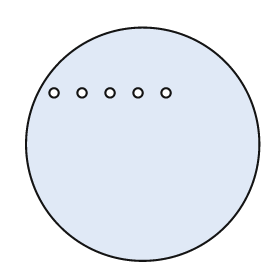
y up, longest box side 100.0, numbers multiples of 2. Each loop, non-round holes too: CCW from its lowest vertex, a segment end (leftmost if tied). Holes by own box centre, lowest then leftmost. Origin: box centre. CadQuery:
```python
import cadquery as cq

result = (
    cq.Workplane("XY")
    .moveTo(0.0, 0.0)
    .circle(50.0)
    .moveTo(-38.0, 22.0)
    .circle(2.0)
    .moveTo(-26.0, 22.0)
    .circle(2.0)
    .moveTo(-14.0, 22.0)
    .circle(2.0)
    .moveTo(-2.0, 22.0)
    .circle(2.0)
    .moveTo(10.0, 22.0)
    .circle(2.0)
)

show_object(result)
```